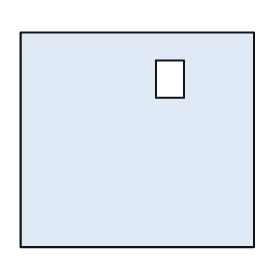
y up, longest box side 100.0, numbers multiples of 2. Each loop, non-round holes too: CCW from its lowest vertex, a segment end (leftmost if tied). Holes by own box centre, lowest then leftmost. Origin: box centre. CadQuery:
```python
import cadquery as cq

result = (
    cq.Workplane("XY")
    .moveTo(-50.0, -46.0)
    .lineTo(50.0, -46.0)
    .lineTo(50.0, 46.0)
    .lineTo(-50.0, 46.0)
    .close()
    .moveTo(8.0, 18.0)
    .lineTo(20.0, 18.0)
    .lineTo(20.0, 34.0)
    .lineTo(8.0, 34.0)
    .close()
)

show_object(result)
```